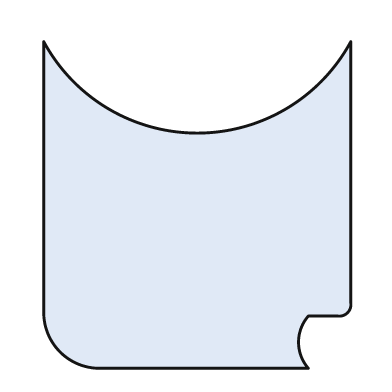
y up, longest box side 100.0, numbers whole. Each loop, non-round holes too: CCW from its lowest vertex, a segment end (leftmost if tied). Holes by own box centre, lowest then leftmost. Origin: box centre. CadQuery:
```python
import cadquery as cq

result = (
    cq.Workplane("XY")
    .moveTo(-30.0, -50.0)
    .lineTo(34.0, -50.0)
    .threePointArc((31.0, -42.0), (34.0, -34.0))
    .lineTo(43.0, -34.0)
    .threePointArc((46.0, -33.0), (47.0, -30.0))
    .lineTo(47.0, 50.0)
    .threePointArc((0.0, 22.0), (-47.0, 50.0))
    .lineTo(-47.0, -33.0)
    .threePointArc((-42.0, -45.0), (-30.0, -50.0))
    .close()
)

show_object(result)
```